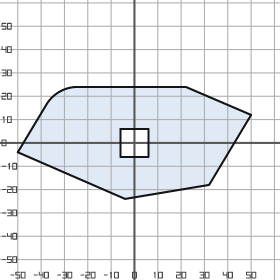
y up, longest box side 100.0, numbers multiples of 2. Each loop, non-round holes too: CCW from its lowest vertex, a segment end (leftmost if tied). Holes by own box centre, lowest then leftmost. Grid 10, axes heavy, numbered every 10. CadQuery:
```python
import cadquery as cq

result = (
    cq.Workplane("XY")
    .moveTo(-4.0, -24.0)
    .lineTo(32.0, -18.0)
    .lineTo(50.0, 12.0)
    .lineTo(22.0, 24.0)
    .lineTo(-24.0, 24.0)
    .threePointArc((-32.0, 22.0), (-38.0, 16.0))
    .lineTo(-50.0, -4.0)
    .close()
    .moveTo(-6.0, -6.0)
    .lineTo(6.0, -6.0)
    .lineTo(6.0, 6.0)
    .lineTo(-6.0, 6.0)
    .close()
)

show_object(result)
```